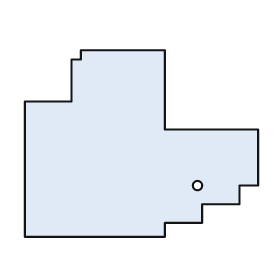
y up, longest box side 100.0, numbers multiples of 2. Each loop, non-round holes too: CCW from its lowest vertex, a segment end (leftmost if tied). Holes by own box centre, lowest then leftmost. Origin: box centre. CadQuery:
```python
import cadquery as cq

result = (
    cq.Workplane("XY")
    .moveTo(-50.0, -40.0)
    .lineTo(10.0, -40.0)
    .lineTo(10.0, -34.0)
    .lineTo(26.0, -34.0)
    .lineTo(26.0, -26.0)
    .lineTo(42.0, -26.0)
    .lineTo(42.0, -18.0)
    .lineTo(50.0, -18.0)
    .lineTo(50.0, 6.0)
    .lineTo(10.0, 6.0)
    .lineTo(10.0, 40.0)
    .lineTo(-26.0, 40.0)
    .lineTo(-26.0, 36.0)
    .lineTo(-30.0, 36.0)
    .lineTo(-30.0, 18.0)
    .lineTo(-50.0, 18.0)
    .close()
    .moveTo(24.0, -18.0)
    .circle(2.0)
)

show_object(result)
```